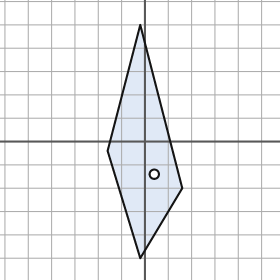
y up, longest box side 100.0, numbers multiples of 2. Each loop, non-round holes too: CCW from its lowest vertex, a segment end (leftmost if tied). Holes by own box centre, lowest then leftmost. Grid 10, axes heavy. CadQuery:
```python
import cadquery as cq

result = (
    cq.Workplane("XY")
    .moveTo(-2.0, -50.0)
    .lineTo(16.0, -20.0)
    .lineTo(-2.0, 50.0)
    .lineTo(-16.0, -4.0)
    .close()
    .moveTo(4.0, -14.0)
    .circle(2.0)
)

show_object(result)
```